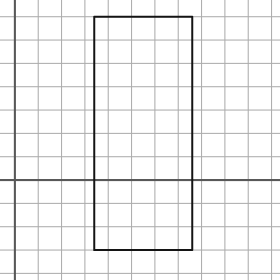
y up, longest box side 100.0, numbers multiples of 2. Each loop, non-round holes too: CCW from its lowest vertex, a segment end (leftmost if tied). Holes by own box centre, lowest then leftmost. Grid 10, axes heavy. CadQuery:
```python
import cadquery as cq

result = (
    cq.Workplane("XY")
    .moveTo(34.0, -30.0)
    .lineTo(76.0, -30.0)
    .lineTo(76.0, 70.0)
    .lineTo(34.0, 70.0)
    .close()
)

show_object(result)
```